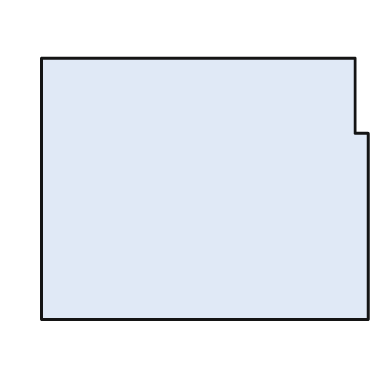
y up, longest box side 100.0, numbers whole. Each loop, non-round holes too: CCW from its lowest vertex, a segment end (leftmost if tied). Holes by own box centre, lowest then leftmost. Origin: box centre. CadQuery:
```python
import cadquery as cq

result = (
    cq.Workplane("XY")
    .moveTo(-50.0, -40.0)
    .lineTo(50.0, -40.0)
    .lineTo(50.0, 17.0)
    .lineTo(46.0, 17.0)
    .lineTo(46.0, 40.0)
    .lineTo(-50.0, 40.0)
    .close()
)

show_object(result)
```